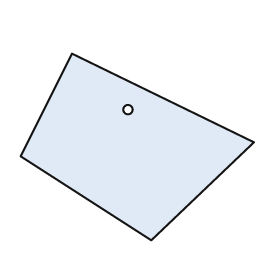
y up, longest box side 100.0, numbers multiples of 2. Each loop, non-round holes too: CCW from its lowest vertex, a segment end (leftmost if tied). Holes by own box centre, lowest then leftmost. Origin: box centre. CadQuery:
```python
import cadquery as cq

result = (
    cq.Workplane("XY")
    .moveTo(6.0, -40.0)
    .lineTo(50.0, 2.0)
    .lineTo(-28.0, 40.0)
    .lineTo(-50.0, -4.0)
    .close()
    .moveTo(-4.0, 16.0)
    .circle(2.0)
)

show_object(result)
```